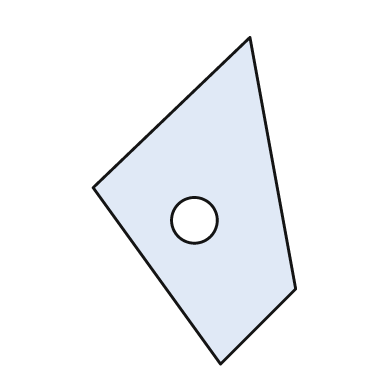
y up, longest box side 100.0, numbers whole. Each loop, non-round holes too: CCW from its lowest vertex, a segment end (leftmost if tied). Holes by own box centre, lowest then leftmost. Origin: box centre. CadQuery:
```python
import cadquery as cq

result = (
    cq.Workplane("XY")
    .moveTo(8.0, -50.0)
    .lineTo(31.0, -27.0)
    .lineTo(17.0, 50.0)
    .lineTo(-31.0, 4.0)
    .close()
    .moveTo(0.0, -6.0)
    .circle(7.0)
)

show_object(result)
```